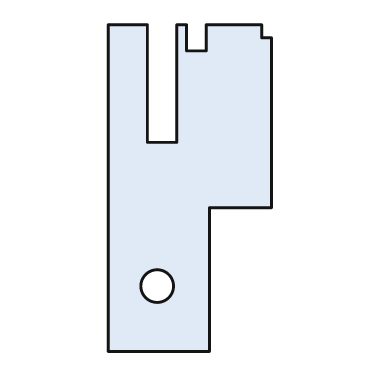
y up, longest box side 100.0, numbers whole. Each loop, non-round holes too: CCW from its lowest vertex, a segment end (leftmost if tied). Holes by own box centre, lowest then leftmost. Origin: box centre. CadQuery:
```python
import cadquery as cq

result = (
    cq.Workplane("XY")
    .moveTo(-25.0, -50.0)
    .lineTo(6.0, -50.0)
    .lineTo(6.0, -6.0)
    .lineTo(25.0, -6.0)
    .lineTo(25.0, 46.0)
    .lineTo(22.0, 46.0)
    .lineTo(22.0, 50.0)
    .lineTo(5.0, 50.0)
    .lineTo(5.0, 42.0)
    .lineTo(-1.0, 42.0)
    .lineTo(-1.0, 50.0)
    .lineTo(-4.0, 50.0)
    .lineTo(-4.0, 14.0)
    .lineTo(-13.0, 14.0)
    .lineTo(-13.0, 50.0)
    .lineTo(-25.0, 50.0)
    .close()
    .moveTo(-10.0, -30.0)
    .circle(5.0)
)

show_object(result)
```